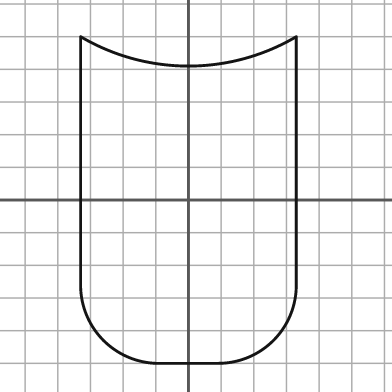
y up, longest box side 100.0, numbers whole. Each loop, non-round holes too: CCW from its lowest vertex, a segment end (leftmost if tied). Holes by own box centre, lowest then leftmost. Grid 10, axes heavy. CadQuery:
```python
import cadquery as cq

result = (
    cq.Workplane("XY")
    .moveTo(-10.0, -50.0)
    .lineTo(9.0, -50.0)
    .threePointArc((26.0, -43.0), (33.0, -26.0))
    .lineTo(33.0, 50.0)
    .threePointArc((0.0, 41.0), (-33.0, 50.0))
    .lineTo(-33.0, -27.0)
    .threePointArc((-26.0, -43.0), (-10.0, -50.0))
    .close()
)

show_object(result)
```